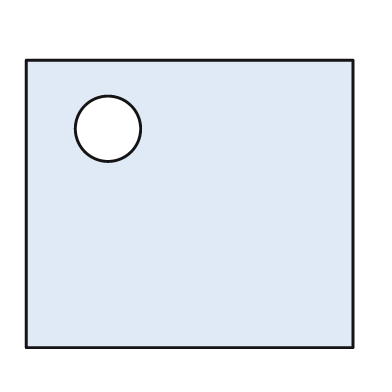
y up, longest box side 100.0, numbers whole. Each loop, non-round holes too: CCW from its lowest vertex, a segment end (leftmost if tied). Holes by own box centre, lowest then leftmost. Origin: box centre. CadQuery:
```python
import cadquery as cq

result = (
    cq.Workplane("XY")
    .moveTo(-50.0, -44.0)
    .lineTo(50.0, -44.0)
    .lineTo(50.0, 44.0)
    .lineTo(-50.0, 44.0)
    .close()
    .moveTo(-25.0, 23.0)
    .circle(10.0)
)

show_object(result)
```